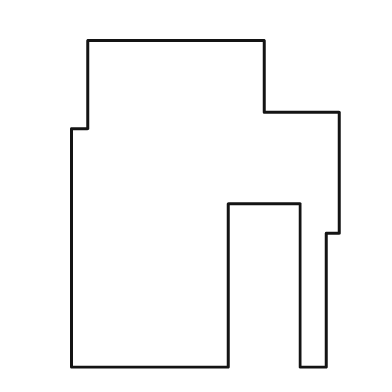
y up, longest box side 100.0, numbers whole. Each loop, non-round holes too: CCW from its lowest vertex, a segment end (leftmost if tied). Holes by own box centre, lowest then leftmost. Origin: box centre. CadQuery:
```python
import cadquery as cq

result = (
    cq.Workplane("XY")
    .moveTo(-41.0, -50.0)
    .lineTo(7.0, -50.0)
    .lineTo(7.0, 0.0)
    .lineTo(29.0, 0.0)
    .lineTo(29.0, -50.0)
    .lineTo(37.0, -50.0)
    .lineTo(37.0, -9.0)
    .lineTo(41.0, -9.0)
    .lineTo(41.0, 28.0)
    .lineTo(18.0, 28.0)
    .lineTo(18.0, 50.0)
    .lineTo(-36.0, 50.0)
    .lineTo(-36.0, 23.0)
    .lineTo(-41.0, 23.0)
    .close()
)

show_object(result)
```